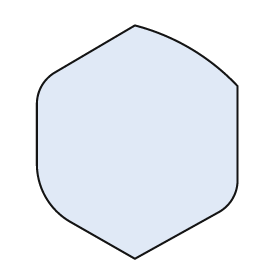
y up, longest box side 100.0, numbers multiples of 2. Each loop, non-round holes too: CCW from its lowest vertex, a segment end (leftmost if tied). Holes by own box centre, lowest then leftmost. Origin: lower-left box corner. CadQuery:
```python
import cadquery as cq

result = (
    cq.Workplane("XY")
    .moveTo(42.0, 0.0)
    .lineTo(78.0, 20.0)
    .threePointArc((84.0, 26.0), (86.0, 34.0))
    .lineTo(86.0, 74.0)
    .threePointArc((66.0, 90.0), (42.0, 100.0))
    .lineTo(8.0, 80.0)
    .threePointArc((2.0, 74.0), (0.0, 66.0))
    .lineTo(0.0, 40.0)
    .threePointArc((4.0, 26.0), (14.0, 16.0))
    .close()
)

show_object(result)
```